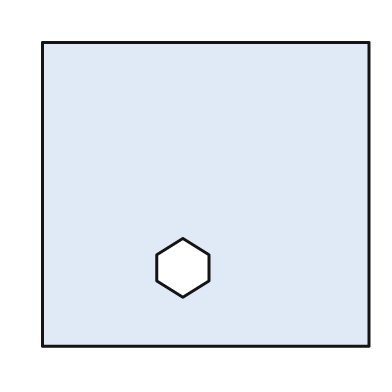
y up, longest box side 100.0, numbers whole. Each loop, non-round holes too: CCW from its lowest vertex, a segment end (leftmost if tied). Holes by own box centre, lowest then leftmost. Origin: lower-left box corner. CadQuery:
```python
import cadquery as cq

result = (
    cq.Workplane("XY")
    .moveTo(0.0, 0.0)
    .lineTo(100.0, 0.0)
    .lineTo(100.0, 93.0)
    .lineTo(0.0, 93.0)
    .close()
    .moveTo(43.0, 15.0)
    .lineTo(51.0, 20.0)
    .lineTo(51.0, 28.0)
    .lineTo(43.0, 33.0)
    .lineTo(35.0, 28.0)
    .lineTo(35.0, 20.0)
    .close()
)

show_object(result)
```